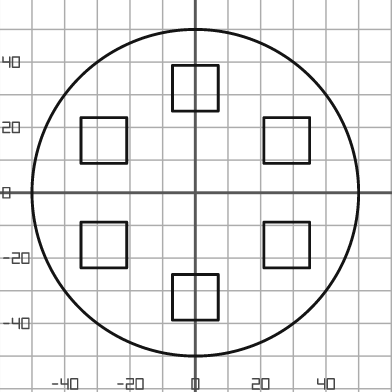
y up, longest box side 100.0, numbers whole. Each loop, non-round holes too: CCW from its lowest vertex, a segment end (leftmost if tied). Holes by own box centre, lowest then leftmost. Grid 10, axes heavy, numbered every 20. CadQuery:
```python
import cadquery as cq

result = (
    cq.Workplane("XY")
    .moveTo(0.0, 0.0)
    .circle(50.0)
    .moveTo(-7.0, -39.0)
    .lineTo(7.0, -39.0)
    .lineTo(7.0, -25.0)
    .lineTo(-7.0, -25.0)
    .close()
    .moveTo(-35.0, -23.0)
    .lineTo(-21.0, -23.0)
    .lineTo(-21.0, -9.0)
    .lineTo(-35.0, -9.0)
    .close()
    .moveTo(21.0, -23.0)
    .lineTo(35.0, -23.0)
    .lineTo(35.0, -9.0)
    .lineTo(21.0, -9.0)
    .close()
    .moveTo(-35.0, 9.0)
    .lineTo(-21.0, 9.0)
    .lineTo(-21.0, 23.0)
    .lineTo(-35.0, 23.0)
    .close()
    .moveTo(21.0, 9.0)
    .lineTo(35.0, 9.0)
    .lineTo(35.0, 23.0)
    .lineTo(21.0, 23.0)
    .close()
    .moveTo(-7.0, 25.0)
    .lineTo(7.0, 25.0)
    .lineTo(7.0, 39.0)
    .lineTo(-7.0, 39.0)
    .close()
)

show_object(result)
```